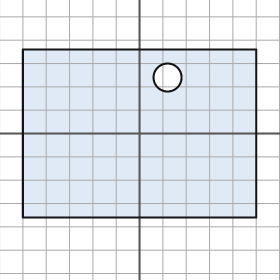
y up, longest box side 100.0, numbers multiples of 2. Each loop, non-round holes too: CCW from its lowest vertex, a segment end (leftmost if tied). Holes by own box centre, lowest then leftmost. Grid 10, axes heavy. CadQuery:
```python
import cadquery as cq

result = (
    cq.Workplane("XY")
    .moveTo(-50.0, -36.0)
    .lineTo(50.0, -36.0)
    .lineTo(50.0, 36.0)
    .lineTo(-50.0, 36.0)
    .close()
    .moveTo(12.0, 24.0)
    .circle(6.0)
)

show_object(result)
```